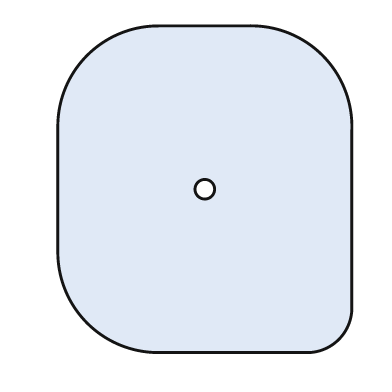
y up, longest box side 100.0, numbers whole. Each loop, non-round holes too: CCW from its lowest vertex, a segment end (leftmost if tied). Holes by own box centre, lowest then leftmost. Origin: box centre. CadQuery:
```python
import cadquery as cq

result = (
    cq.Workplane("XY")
    .moveTo(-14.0, -50.0)
    .lineTo(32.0, -50.0)
    .threePointArc((41.0, -46.0), (45.0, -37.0))
    .lineTo(45.0, 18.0)
    .threePointArc((36.0, 41.0), (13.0, 50.0))
    .lineTo(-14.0, 50.0)
    .threePointArc((-36.0, 41.0), (-45.0, 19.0))
    .lineTo(-45.0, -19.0)
    .threePointArc((-36.0, -41.0), (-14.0, -50.0))
    .close()
    .moveTo(0.0, 0.0)
    .circle(3.0)
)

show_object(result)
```